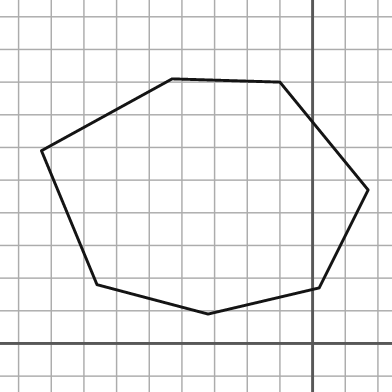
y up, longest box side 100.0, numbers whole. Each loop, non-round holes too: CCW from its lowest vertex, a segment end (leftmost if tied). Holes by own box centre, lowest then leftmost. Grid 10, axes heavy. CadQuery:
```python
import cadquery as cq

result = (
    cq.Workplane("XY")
    .moveTo(-32.0, 9.0)
    .lineTo(2.0, 17.0)
    .lineTo(17.0, 47.0)
    .lineTo(-10.0, 80.0)
    .lineTo(-43.0, 81.0)
    .lineTo(-83.0, 59.0)
    .lineTo(-66.0, 18.0)
    .close()
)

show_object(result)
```